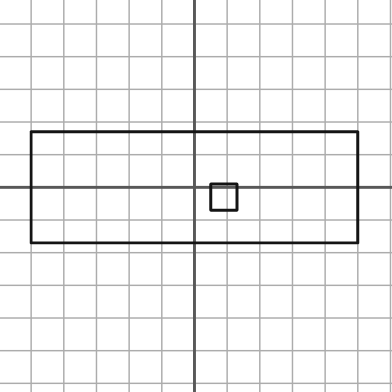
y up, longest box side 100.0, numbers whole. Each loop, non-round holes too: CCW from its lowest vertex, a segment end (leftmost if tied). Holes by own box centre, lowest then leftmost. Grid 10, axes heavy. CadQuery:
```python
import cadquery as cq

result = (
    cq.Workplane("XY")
    .moveTo(-50.0, -17.0)
    .lineTo(50.0, -17.0)
    .lineTo(50.0, 17.0)
    .lineTo(-50.0, 17.0)
    .close()
    .moveTo(5.0, -7.0)
    .lineTo(13.0, -7.0)
    .lineTo(13.0, 1.0)
    .lineTo(5.0, 1.0)
    .close()
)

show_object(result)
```